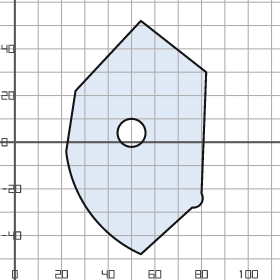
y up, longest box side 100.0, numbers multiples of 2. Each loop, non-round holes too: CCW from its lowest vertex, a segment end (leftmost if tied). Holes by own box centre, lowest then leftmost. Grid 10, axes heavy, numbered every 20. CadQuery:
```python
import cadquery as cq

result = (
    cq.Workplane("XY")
    .moveTo(54.0, -48.0)
    .lineTo(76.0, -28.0)
    .threePointArc((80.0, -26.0), (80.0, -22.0))
    .lineTo(82.0, 30.0)
    .lineTo(54.0, 52.0)
    .lineTo(26.0, 22.0)
    .lineTo(22.0, -4.0)
    .threePointArc((32.0, -30.0), (54.0, -48.0))
    .close()
    .moveTo(50.0, 4.0)
    .circle(6.0)
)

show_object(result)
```